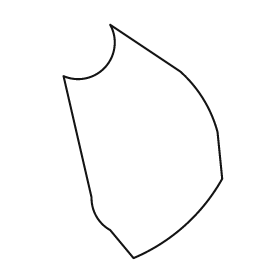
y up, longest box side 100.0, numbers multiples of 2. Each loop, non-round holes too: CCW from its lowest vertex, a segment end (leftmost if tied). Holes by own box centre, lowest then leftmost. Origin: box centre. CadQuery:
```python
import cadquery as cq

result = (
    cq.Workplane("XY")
    .moveTo(-4.0, -50.0)
    .threePointArc((18.0, -36.0), (34.0, -16.0))
    .lineTo(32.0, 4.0)
    .threePointArc((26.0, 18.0), (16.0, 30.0))
    .lineTo(-14.0, 50.0)
    .threePointArc((-16.0, 32.0), (-34.0, 28.0))
    .lineTo(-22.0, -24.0)
    .threePointArc((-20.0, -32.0), (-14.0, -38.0))
    .close()
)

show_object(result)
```